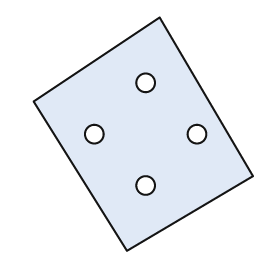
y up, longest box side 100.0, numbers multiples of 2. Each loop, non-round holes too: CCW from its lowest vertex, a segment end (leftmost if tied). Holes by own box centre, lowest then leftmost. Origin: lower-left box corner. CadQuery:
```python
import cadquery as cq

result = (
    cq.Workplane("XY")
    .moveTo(40.0, 0.0)
    .lineTo(94.0, 32.0)
    .lineTo(54.0, 100.0)
    .lineTo(0.0, 64.0)
    .close()
    .moveTo(48.0, 28.0)
    .circle(4.0)
    .moveTo(26.0, 50.0)
    .circle(4.0)
    .moveTo(70.0, 50.0)
    .circle(4.0)
    .moveTo(48.0, 72.0)
    .circle(4.0)
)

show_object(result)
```